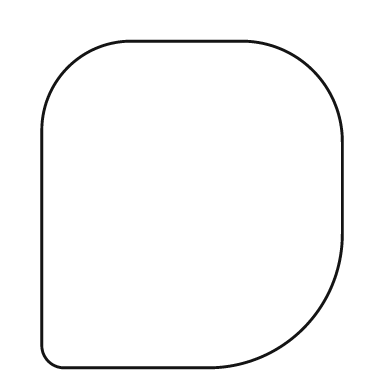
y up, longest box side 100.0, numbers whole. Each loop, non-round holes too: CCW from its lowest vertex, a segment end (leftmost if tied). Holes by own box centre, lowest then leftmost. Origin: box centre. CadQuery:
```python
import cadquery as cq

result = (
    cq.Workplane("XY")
    .moveTo(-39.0, -50.0)
    .lineTo(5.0, -50.0)
    .threePointArc((34.0, -38.0), (46.0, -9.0))
    .lineTo(46.0, 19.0)
    .threePointArc((37.0, 41.0), (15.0, 50.0))
    .lineTo(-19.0, 50.0)
    .threePointArc((-38.0, 42.0), (-46.0, 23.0))
    .lineTo(-46.0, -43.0)
    .threePointArc((-44.0, -48.0), (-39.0, -50.0))
    .close()
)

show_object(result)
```